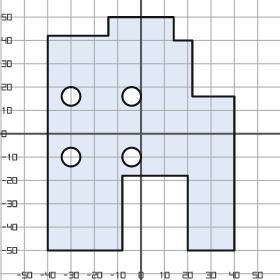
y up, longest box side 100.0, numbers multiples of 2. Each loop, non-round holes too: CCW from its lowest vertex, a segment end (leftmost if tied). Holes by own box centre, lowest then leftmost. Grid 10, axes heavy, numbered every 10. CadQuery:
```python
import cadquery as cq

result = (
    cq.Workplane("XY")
    .moveTo(-40.0, -50.0)
    .lineTo(-8.0, -50.0)
    .lineTo(-8.0, -18.0)
    .lineTo(20.0, -18.0)
    .lineTo(20.0, -50.0)
    .lineTo(40.0, -50.0)
    .lineTo(40.0, 16.0)
    .lineTo(22.0, 16.0)
    .lineTo(22.0, 40.0)
    .lineTo(14.0, 40.0)
    .lineTo(14.0, 50.0)
    .lineTo(-14.0, 50.0)
    .lineTo(-14.0, 42.0)
    .lineTo(-40.0, 42.0)
    .close()
    .moveTo(-30.0, -10.0)
    .circle(4.0)
    .moveTo(-4.0, -10.0)
    .circle(4.0)
    .moveTo(-30.0, 16.0)
    .circle(4.0)
    .moveTo(-4.0, 16.0)
    .circle(4.0)
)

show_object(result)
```